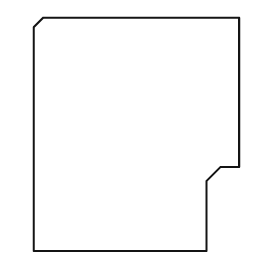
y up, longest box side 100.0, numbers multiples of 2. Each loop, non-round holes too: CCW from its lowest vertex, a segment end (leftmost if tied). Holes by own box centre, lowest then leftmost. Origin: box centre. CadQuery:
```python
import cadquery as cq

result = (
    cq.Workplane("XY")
    .moveTo(-44.0, -50.0)
    .lineTo(30.0, -50.0)
    .lineTo(30.0, -20.0)
    .lineTo(36.0, -14.0)
    .lineTo(44.0, -14.0)
    .lineTo(44.0, 50.0)
    .lineTo(-40.0, 50.0)
    .lineTo(-44.0, 46.0)
    .close()
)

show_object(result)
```